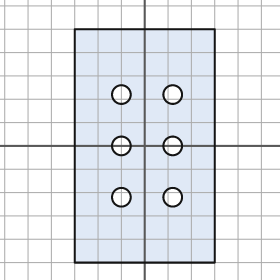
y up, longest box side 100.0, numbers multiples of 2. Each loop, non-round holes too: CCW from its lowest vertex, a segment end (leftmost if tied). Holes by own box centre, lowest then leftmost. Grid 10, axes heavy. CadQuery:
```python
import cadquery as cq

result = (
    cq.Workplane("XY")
    .moveTo(-30.0, -50.0)
    .lineTo(30.0, -50.0)
    .lineTo(30.0, 50.0)
    .lineTo(-30.0, 50.0)
    .close()
    .moveTo(-10.0, -22.0)
    .circle(4.0)
    .moveTo(12.0, -22.0)
    .circle(4.0)
    .moveTo(-10.0, 0.0)
    .circle(4.0)
    .moveTo(12.0, 0.0)
    .circle(4.0)
    .moveTo(-10.0, 22.0)
    .circle(4.0)
    .moveTo(12.0, 22.0)
    .circle(4.0)
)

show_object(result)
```